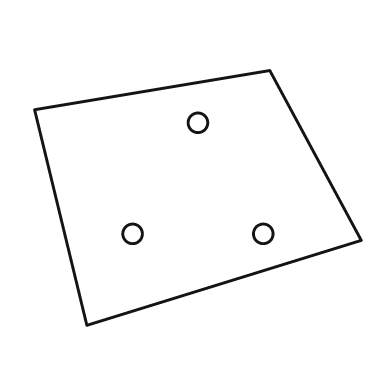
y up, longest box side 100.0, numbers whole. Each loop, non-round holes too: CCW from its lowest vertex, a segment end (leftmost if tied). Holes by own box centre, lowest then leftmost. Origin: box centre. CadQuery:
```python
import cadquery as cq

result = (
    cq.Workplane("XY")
    .moveTo(-34.0, -39.0)
    .lineTo(50.0, -13.0)
    .lineTo(22.0, 39.0)
    .lineTo(-50.0, 27.0)
    .close()
    .moveTo(-20.0, -11.0)
    .circle(3.0)
    .moveTo(20.0, -11.0)
    .circle(3.0)
    .moveTo(0.0, 23.0)
    .circle(3.0)
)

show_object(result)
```